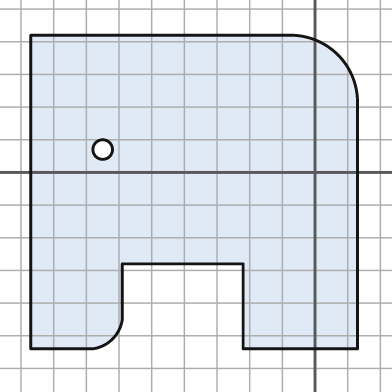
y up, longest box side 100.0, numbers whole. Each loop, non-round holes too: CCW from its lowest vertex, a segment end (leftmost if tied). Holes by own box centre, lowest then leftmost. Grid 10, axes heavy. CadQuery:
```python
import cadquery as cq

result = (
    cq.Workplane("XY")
    .moveTo(-87.0, -54.0)
    .lineTo(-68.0, -54.0)
    .threePointArc((-62.0, -51.0), (-59.0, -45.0))
    .lineTo(-59.0, -28.0)
    .lineTo(-22.0, -28.0)
    .lineTo(-22.0, -54.0)
    .lineTo(13.0, -54.0)
    .lineTo(13.0, 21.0)
    .threePointArc((7.0, 36.0), (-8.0, 42.0))
    .lineTo(-87.0, 42.0)
    .close()
    .moveTo(-65.0, 7.0)
    .circle(3.0)
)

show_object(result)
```